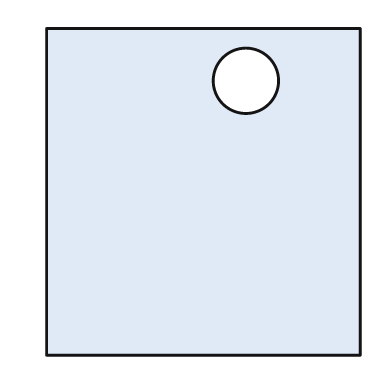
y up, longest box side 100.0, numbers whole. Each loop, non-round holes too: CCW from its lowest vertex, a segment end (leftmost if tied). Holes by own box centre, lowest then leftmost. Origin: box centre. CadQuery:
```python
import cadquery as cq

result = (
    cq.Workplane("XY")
    .moveTo(-48.0, -50.0)
    .lineTo(48.0, -50.0)
    .lineTo(48.0, 50.0)
    .lineTo(-48.0, 50.0)
    .close()
    .moveTo(13.0, 34.0)
    .circle(10.0)
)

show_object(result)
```